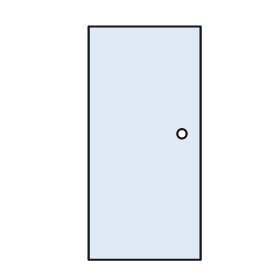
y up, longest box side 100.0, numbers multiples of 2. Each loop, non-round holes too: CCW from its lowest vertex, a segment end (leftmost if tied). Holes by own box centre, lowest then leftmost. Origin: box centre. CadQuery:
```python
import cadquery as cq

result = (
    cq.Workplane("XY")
    .moveTo(-24.0, -50.0)
    .lineTo(24.0, -50.0)
    .lineTo(24.0, 50.0)
    .lineTo(-24.0, 50.0)
    .close()
    .moveTo(16.0, 4.0)
    .circle(2.0)
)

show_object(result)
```